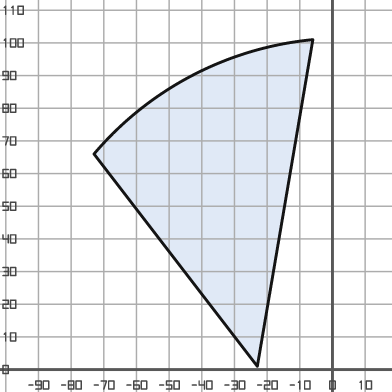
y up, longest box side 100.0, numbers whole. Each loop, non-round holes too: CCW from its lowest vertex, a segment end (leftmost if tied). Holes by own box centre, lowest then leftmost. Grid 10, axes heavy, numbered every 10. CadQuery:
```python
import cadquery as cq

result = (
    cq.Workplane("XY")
    .moveTo(-23.0, 1.0)
    .lineTo(-6.0, 101.0)
    .threePointArc((-43.0, 90.0), (-73.0, 66.0))
    .close()
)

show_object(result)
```